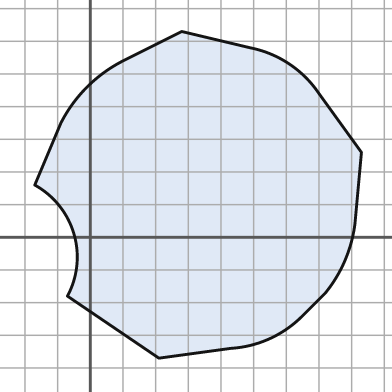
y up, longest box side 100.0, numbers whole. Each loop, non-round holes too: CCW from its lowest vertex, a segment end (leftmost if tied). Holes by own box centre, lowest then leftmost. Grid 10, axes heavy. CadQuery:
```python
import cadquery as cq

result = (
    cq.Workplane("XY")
    .moveTo(21.0, -37.0)
    .lineTo(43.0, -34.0)
    .threePointArc((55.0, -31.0), (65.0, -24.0))
    .lineTo(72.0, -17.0)
    .threePointArc((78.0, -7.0), (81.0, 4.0))
    .lineTo(83.0, 26.0)
    .lineTo(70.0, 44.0)
    .threePointArc((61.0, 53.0), (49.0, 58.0))
    .lineTo(28.0, 63.0)
    .lineTo(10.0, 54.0)
    .threePointArc((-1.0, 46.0), (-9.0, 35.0))
    .lineTo(-17.0, 16.0)
    .threePointArc((-5.0, 1.0), (-7.0, -18.0))
    .close()
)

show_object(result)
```